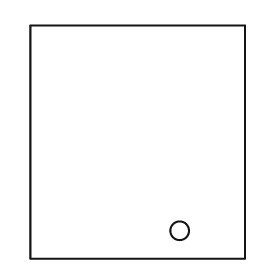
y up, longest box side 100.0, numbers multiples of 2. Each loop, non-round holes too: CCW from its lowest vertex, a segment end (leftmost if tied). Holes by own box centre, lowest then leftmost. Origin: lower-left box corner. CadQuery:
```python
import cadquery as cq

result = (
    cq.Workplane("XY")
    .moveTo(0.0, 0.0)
    .lineTo(92.0, 0.0)
    .lineTo(92.0, 100.0)
    .lineTo(0.0, 100.0)
    .close()
    .moveTo(64.0, 12.0)
    .circle(4.0)
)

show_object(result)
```